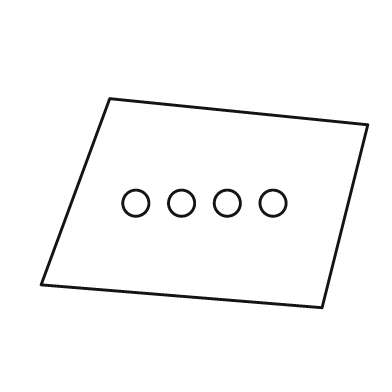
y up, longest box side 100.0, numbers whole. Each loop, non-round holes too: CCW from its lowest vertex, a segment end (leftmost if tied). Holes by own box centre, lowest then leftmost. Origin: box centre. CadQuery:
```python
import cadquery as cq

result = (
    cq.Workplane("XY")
    .moveTo(36.0, -32.0)
    .lineTo(50.0, 24.0)
    .lineTo(-29.0, 32.0)
    .lineTo(-50.0, -25.0)
    .close()
    .moveTo(-21.0, 0.0)
    .circle(4.0)
    .moveTo(-7.0, 0.0)
    .circle(4.0)
    .moveTo(7.0, 0.0)
    .circle(4.0)
    .moveTo(21.0, 0.0)
    .circle(4.0)
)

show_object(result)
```